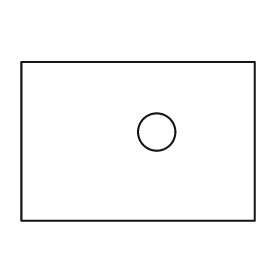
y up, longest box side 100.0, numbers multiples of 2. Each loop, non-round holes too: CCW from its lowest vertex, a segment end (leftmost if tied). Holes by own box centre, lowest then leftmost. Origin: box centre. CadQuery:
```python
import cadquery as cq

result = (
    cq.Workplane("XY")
    .moveTo(-50.0, -34.0)
    .lineTo(50.0, -34.0)
    .lineTo(50.0, 34.0)
    .lineTo(-50.0, 34.0)
    .close()
    .moveTo(8.0, 4.0)
    .circle(8.0)
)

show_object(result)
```